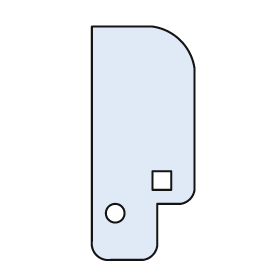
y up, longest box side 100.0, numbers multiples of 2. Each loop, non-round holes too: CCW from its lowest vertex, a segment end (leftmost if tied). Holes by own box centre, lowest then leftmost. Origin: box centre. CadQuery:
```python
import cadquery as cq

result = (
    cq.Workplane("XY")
    .moveTo(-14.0, -50.0)
    .lineTo(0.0, -50.0)
    .threePointArc((4.0, -48.0), (6.0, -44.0))
    .lineTo(6.0, -26.0)
    .lineTo(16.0, -26.0)
    .threePointArc((20.0, -24.0), (22.0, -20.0))
    .lineTo(22.0, 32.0)
    .threePointArc((16.0, 44.0), (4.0, 50.0))
    .lineTo(-22.0, 50.0)
    .lineTo(-22.0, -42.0)
    .threePointArc((-20.0, -48.0), (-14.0, -50.0))
    .close()
    .moveTo(-12.0, -30.0)
    .circle(4.0)
    .moveTo(4.0, -20.0)
    .lineTo(12.0, -20.0)
    .lineTo(12.0, -12.0)
    .lineTo(4.0, -12.0)
    .close()
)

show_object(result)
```